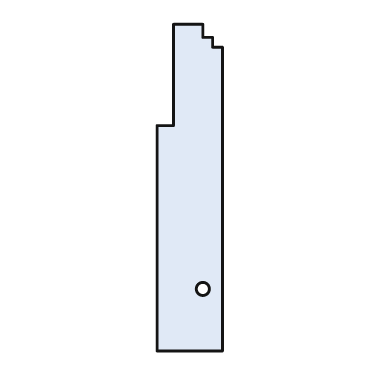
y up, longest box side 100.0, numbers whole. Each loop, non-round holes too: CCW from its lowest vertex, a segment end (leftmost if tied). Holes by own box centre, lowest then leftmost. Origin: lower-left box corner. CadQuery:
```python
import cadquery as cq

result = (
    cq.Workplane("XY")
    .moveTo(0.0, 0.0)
    .lineTo(20.0, 0.0)
    .lineTo(20.0, 93.0)
    .lineTo(17.0, 93.0)
    .lineTo(17.0, 96.0)
    .lineTo(14.0, 96.0)
    .lineTo(14.0, 100.0)
    .lineTo(5.0, 100.0)
    .lineTo(5.0, 69.0)
    .lineTo(0.0, 69.0)
    .close()
    .moveTo(14.0, 19.0)
    .circle(2.0)
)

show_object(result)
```